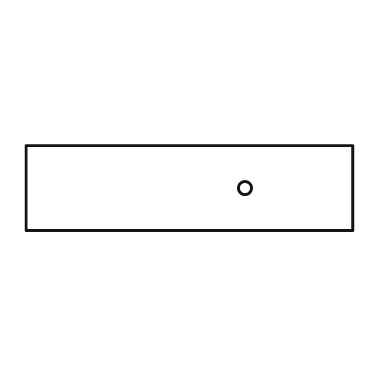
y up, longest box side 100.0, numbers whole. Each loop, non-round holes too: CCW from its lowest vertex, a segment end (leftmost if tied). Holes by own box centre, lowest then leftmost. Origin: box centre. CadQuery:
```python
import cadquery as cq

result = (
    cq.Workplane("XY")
    .moveTo(-50.0, -13.0)
    .lineTo(50.0, -13.0)
    .lineTo(50.0, 13.0)
    .lineTo(-50.0, 13.0)
    .close()
    .moveTo(17.0, 0.0)
    .circle(2.0)
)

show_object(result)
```